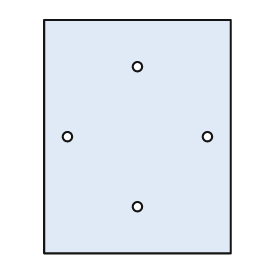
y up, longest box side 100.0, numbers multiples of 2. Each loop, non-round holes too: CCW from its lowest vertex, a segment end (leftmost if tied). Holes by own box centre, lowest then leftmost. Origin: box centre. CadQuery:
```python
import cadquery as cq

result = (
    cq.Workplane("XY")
    .moveTo(-40.0, -50.0)
    .lineTo(40.0, -50.0)
    .lineTo(40.0, 50.0)
    .lineTo(-40.0, 50.0)
    .close()
    .moveTo(0.0, -30.0)
    .circle(2.0)
    .moveTo(-30.0, 0.0)
    .circle(2.0)
    .moveTo(30.0, 0.0)
    .circle(2.0)
    .moveTo(0.0, 30.0)
    .circle(2.0)
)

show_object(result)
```